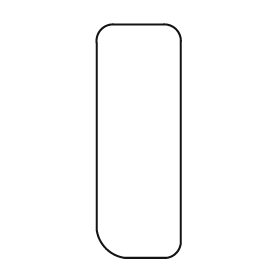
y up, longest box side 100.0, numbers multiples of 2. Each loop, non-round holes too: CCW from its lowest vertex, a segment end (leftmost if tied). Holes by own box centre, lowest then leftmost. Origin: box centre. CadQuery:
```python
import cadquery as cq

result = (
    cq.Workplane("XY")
    .moveTo(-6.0, -50.0)
    .lineTo(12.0, -50.0)
    .threePointArc((16.0, -48.0), (18.0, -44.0))
    .lineTo(18.0, 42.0)
    .threePointArc((16.0, 48.0), (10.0, 50.0))
    .lineTo(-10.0, 50.0)
    .threePointArc((-16.0, 48.0), (-18.0, 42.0))
    .lineTo(-18.0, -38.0)
    .threePointArc((-14.0, -46.0), (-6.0, -50.0))
    .close()
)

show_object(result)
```